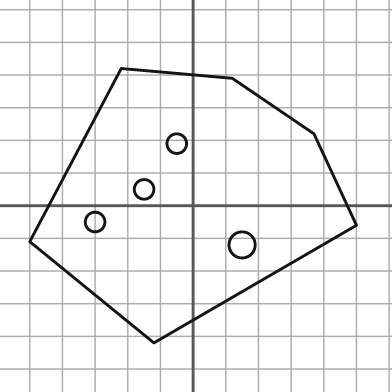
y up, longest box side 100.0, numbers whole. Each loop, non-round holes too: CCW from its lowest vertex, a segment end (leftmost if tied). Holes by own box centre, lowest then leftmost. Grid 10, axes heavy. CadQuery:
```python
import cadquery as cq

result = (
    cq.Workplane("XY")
    .moveTo(-12.0, -42.0)
    .lineTo(50.0, -6.0)
    .lineTo(37.0, 22.0)
    .lineTo(12.0, 39.0)
    .lineTo(-22.0, 42.0)
    .lineTo(-50.0, -11.0)
    .close()
    .moveTo(15.0, -12.0)
    .circle(4.0)
    .moveTo(-30.0, -5.0)
    .circle(3.0)
    .moveTo(-15.0, 5.0)
    .circle(3.0)
    .moveTo(-5.0, 19.0)
    .circle(3.0)
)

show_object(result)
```